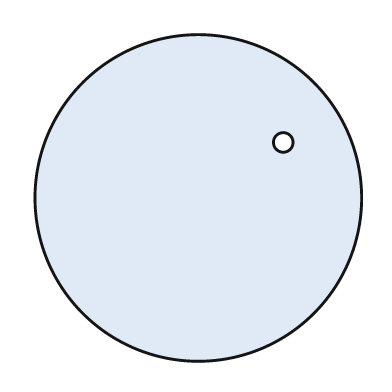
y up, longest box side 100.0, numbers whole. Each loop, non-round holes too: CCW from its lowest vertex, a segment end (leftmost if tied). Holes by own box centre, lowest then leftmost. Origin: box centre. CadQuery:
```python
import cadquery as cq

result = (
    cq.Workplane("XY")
    .moveTo(0.0, 0.0)
    .circle(50.0)
    .moveTo(26.0, 17.0)
    .circle(3.0)
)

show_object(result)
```